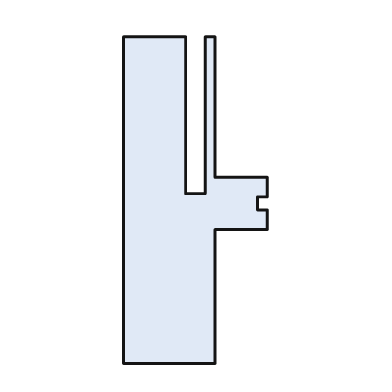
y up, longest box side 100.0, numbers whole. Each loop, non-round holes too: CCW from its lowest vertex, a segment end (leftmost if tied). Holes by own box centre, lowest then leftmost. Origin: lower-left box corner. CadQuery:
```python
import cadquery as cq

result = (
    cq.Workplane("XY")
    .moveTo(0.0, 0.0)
    .lineTo(28.0, 0.0)
    .lineTo(28.0, 41.0)
    .lineTo(44.0, 41.0)
    .lineTo(44.0, 47.0)
    .lineTo(41.0, 47.0)
    .lineTo(41.0, 51.0)
    .lineTo(44.0, 51.0)
    .lineTo(44.0, 57.0)
    .lineTo(28.0, 57.0)
    .lineTo(28.0, 100.0)
    .lineTo(25.0, 100.0)
    .lineTo(25.0, 52.0)
    .lineTo(19.0, 52.0)
    .lineTo(19.0, 100.0)
    .lineTo(0.0, 100.0)
    .close()
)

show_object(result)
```